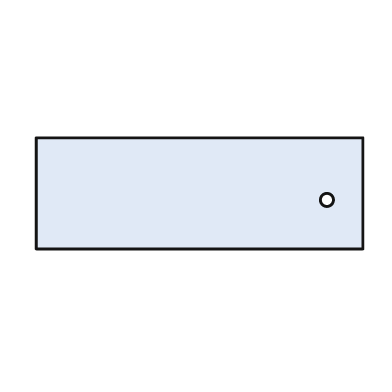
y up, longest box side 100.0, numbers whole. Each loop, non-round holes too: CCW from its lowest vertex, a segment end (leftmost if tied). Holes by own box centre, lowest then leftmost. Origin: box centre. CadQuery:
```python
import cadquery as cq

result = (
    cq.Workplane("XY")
    .moveTo(-50.0, -17.0)
    .lineTo(50.0, -17.0)
    .lineTo(50.0, 17.0)
    .lineTo(-50.0, 17.0)
    .close()
    .moveTo(39.0, -2.0)
    .circle(2.0)
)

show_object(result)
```